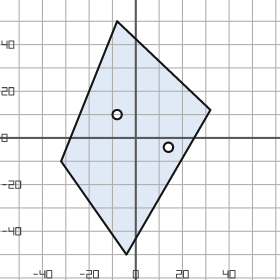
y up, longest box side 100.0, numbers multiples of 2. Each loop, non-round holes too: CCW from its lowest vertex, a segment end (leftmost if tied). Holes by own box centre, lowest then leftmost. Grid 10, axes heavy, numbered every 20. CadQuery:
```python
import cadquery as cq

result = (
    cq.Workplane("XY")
    .moveTo(-4.0, -50.0)
    .lineTo(32.0, 12.0)
    .lineTo(-8.0, 50.0)
    .lineTo(-32.0, -10.0)
    .close()
    .moveTo(14.0, -4.0)
    .circle(2.0)
    .moveTo(-8.0, 10.0)
    .circle(2.0)
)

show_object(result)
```